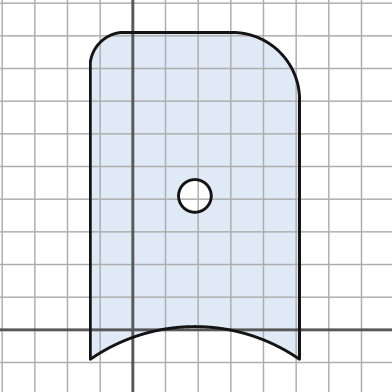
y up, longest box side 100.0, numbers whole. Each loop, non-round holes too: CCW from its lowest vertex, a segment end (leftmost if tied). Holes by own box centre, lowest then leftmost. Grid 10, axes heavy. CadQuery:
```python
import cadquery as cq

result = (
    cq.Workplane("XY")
    .moveTo(-13.0, -9.0)
    .threePointArc((19.0, 1.0), (51.0, -9.0))
    .lineTo(51.0, 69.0)
    .threePointArc((45.0, 85.0), (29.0, 91.0))
    .lineTo(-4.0, 91.0)
    .threePointArc((-10.0, 88.0), (-13.0, 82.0))
    .close()
    .moveTo(19.0, 41.0)
    .circle(5.0)
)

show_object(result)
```